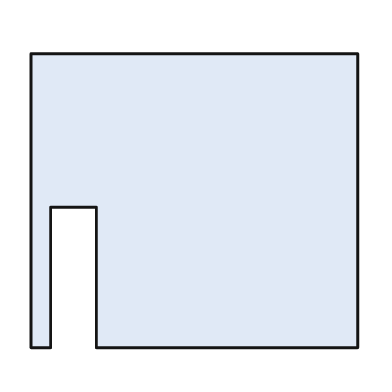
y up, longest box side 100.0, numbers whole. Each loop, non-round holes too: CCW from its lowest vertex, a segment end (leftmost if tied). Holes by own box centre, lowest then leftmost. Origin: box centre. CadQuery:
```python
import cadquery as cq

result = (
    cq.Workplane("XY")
    .moveTo(-50.0, -45.0)
    .lineTo(-44.0, -45.0)
    .lineTo(-44.0, -2.0)
    .lineTo(-30.0, -2.0)
    .lineTo(-30.0, -45.0)
    .lineTo(50.0, -45.0)
    .lineTo(50.0, 45.0)
    .lineTo(-50.0, 45.0)
    .close()
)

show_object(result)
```